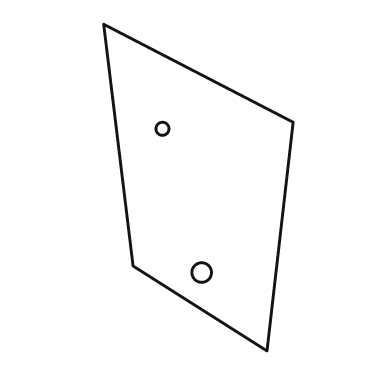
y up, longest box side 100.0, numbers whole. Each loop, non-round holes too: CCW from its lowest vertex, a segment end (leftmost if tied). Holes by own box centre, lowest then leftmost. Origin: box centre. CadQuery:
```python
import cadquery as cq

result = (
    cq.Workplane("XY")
    .moveTo(21.0, -50.0)
    .lineTo(29.0, 20.0)
    .lineTo(-29.0, 50.0)
    .lineTo(-20.0, -24.0)
    .close()
    .moveTo(1.0, -26.0)
    .circle(3.0)
    .moveTo(-11.0, 18.0)
    .circle(2.0)
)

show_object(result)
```